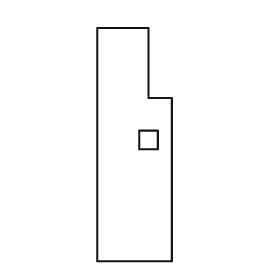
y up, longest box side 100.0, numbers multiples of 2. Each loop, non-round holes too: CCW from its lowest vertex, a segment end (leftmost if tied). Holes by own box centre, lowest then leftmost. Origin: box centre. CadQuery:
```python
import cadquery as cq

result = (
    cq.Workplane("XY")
    .moveTo(-16.0, -50.0)
    .lineTo(16.0, -50.0)
    .lineTo(16.0, 20.0)
    .lineTo(6.0, 20.0)
    .lineTo(6.0, 50.0)
    .lineTo(-16.0, 50.0)
    .close()
    .moveTo(2.0, -2.0)
    .lineTo(10.0, -2.0)
    .lineTo(10.0, 6.0)
    .lineTo(2.0, 6.0)
    .close()
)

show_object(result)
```